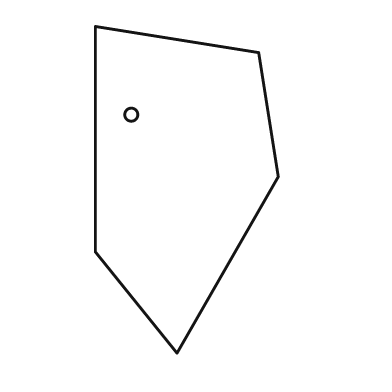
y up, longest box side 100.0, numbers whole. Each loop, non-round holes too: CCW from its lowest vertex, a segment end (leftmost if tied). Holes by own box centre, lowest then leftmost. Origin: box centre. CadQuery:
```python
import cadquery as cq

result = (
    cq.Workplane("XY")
    .moveTo(-3.0, -50.0)
    .lineTo(28.0, 4.0)
    .lineTo(22.0, 42.0)
    .lineTo(-28.0, 50.0)
    .lineTo(-28.0, -19.0)
    .close()
    .moveTo(-17.0, 23.0)
    .circle(2.0)
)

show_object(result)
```